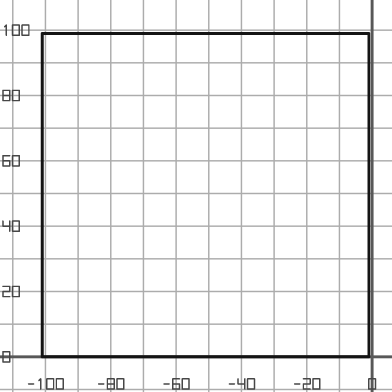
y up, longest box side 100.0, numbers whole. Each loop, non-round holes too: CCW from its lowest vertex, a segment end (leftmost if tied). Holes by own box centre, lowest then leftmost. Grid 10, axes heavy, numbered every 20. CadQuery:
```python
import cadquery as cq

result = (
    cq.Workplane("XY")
    .moveTo(-101.0, 0.0)
    .lineTo(-1.0, 0.0)
    .lineTo(-1.0, 99.0)
    .lineTo(-101.0, 99.0)
    .close()
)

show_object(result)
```